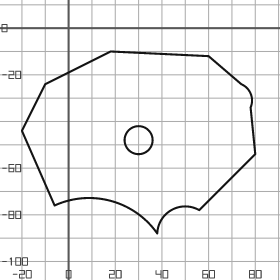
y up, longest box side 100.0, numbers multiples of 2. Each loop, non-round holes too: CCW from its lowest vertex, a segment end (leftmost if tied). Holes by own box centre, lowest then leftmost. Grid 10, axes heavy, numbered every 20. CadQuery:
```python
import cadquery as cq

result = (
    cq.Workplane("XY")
    .moveTo(38.0, -88.0)
    .threePointArc((44.0, -78.0), (56.0, -78.0))
    .lineTo(80.0, -54.0)
    .lineTo(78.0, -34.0)
    .threePointArc((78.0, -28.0), (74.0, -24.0))
    .lineTo(60.0, -12.0)
    .lineTo(18.0, -10.0)
    .lineTo(-10.0, -24.0)
    .lineTo(-20.0, -44.0)
    .lineTo(-6.0, -76.0)
    .threePointArc((18.0, -74.0), (38.0, -88.0))
    .close()
    .moveTo(30.0, -48.0)
    .circle(6.0)
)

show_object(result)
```